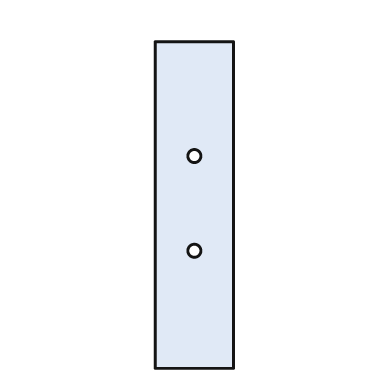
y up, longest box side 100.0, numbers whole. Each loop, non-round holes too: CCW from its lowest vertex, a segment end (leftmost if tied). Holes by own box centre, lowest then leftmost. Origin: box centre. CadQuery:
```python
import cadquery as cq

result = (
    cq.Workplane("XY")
    .moveTo(-12.0, -50.0)
    .lineTo(12.0, -50.0)
    .lineTo(12.0, 50.0)
    .lineTo(-12.0, 50.0)
    .close()
    .moveTo(0.0, -14.0)
    .circle(2.0)
    .moveTo(0.0, 15.0)
    .circle(2.0)
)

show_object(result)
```